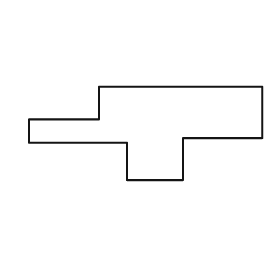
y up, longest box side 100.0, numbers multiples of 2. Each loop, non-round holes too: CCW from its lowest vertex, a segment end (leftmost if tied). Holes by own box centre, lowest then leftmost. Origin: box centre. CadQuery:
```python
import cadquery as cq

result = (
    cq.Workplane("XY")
    .moveTo(-8.0, -20.0)
    .lineTo(16.0, -20.0)
    .lineTo(16.0, -2.0)
    .lineTo(50.0, -2.0)
    .lineTo(50.0, 20.0)
    .lineTo(-20.0, 20.0)
    .lineTo(-20.0, 6.0)
    .lineTo(-50.0, 6.0)
    .lineTo(-50.0, -4.0)
    .lineTo(-8.0, -4.0)
    .close()
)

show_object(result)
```